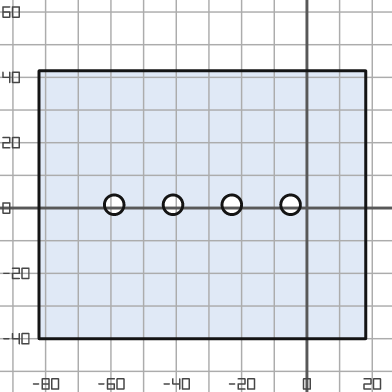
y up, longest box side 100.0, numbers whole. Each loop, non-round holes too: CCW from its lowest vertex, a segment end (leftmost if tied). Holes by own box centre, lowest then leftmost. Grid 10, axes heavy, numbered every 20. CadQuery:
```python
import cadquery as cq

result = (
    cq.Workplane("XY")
    .moveTo(-82.0, -40.0)
    .lineTo(18.0, -40.0)
    .lineTo(18.0, 42.0)
    .lineTo(-82.0, 42.0)
    .close()
    .moveTo(-59.0, 1.0)
    .circle(3.0)
    .moveTo(-41.0, 1.0)
    .circle(3.0)
    .moveTo(-23.0, 1.0)
    .circle(3.0)
    .moveTo(-5.0, 1.0)
    .circle(3.0)
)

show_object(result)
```